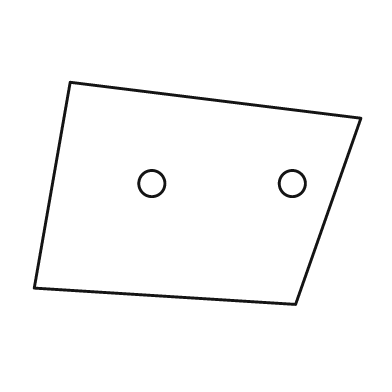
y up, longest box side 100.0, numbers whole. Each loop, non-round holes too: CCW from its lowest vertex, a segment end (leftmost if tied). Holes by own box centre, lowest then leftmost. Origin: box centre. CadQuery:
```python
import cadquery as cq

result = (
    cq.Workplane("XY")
    .moveTo(30.0, -34.0)
    .lineTo(50.0, 23.0)
    .lineTo(-39.0, 34.0)
    .lineTo(-50.0, -29.0)
    .close()
    .moveTo(-14.0, 3.0)
    .circle(4.0)
    .moveTo(29.0, 3.0)
    .circle(4.0)
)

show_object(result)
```